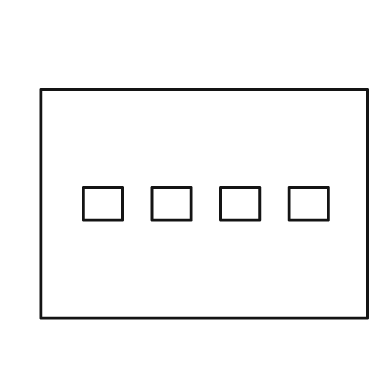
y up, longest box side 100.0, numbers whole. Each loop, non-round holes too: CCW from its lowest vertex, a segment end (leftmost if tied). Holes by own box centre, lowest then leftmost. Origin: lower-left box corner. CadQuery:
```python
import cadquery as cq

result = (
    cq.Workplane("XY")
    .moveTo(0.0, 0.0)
    .lineTo(100.0, 0.0)
    .lineTo(100.0, 70.0)
    .lineTo(0.0, 70.0)
    .close()
    .moveTo(13.0, 30.0)
    .lineTo(25.0, 30.0)
    .lineTo(25.0, 40.0)
    .lineTo(13.0, 40.0)
    .close()
    .moveTo(34.0, 30.0)
    .lineTo(46.0, 30.0)
    .lineTo(46.0, 40.0)
    .lineTo(34.0, 40.0)
    .close()
    .moveTo(55.0, 30.0)
    .lineTo(67.0, 30.0)
    .lineTo(67.0, 40.0)
    .lineTo(55.0, 40.0)
    .close()
    .moveTo(76.0, 30.0)
    .lineTo(88.0, 30.0)
    .lineTo(88.0, 40.0)
    .lineTo(76.0, 40.0)
    .close()
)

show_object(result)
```